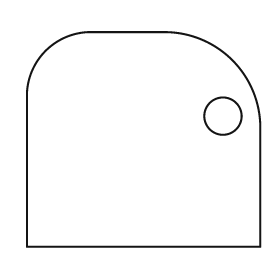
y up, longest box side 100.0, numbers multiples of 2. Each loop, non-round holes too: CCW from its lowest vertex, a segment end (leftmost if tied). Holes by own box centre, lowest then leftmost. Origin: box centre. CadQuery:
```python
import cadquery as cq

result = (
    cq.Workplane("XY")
    .moveTo(-50.0, -46.0)
    .lineTo(50.0, -46.0)
    .lineTo(50.0, 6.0)
    .threePointArc((38.0, 34.0), (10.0, 46.0))
    .lineTo(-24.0, 46.0)
    .threePointArc((-42.0, 38.0), (-50.0, 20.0))
    .close()
    .moveTo(34.0, 10.0)
    .circle(8.0)
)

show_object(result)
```